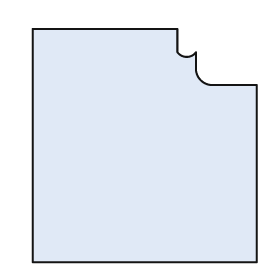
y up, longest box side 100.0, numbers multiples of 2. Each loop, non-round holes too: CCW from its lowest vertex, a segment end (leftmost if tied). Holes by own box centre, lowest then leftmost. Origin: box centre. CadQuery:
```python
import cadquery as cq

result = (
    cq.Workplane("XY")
    .moveTo(-48.0, -50.0)
    .lineTo(48.0, -50.0)
    .lineTo(48.0, 26.0)
    .lineTo(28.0, 26.0)
    .threePointArc((24.0, 28.0), (22.0, 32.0))
    .lineTo(22.0, 40.0)
    .threePointArc((18.0, 38.0), (14.0, 40.0))
    .lineTo(14.0, 50.0)
    .lineTo(-48.0, 50.0)
    .close()
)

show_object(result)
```